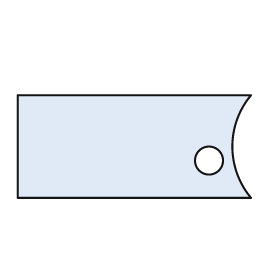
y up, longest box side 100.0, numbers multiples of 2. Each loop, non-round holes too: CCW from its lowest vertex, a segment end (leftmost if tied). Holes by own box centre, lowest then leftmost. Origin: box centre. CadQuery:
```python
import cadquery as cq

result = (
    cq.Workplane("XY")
    .moveTo(-50.0, -22.0)
    .lineTo(50.0, -22.0)
    .threePointArc((42.0, 0.0), (50.0, 22.0))
    .lineTo(-50.0, 22.0)
    .close()
    .moveTo(32.0, -6.0)
    .circle(6.0)
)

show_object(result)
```